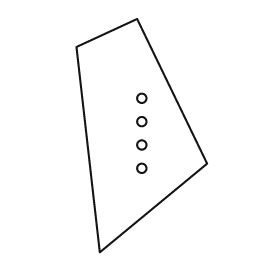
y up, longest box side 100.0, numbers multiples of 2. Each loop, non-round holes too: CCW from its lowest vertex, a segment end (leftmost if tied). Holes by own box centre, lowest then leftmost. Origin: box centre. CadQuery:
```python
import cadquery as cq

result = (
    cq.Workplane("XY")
    .moveTo(-18.0, -50.0)
    .lineTo(28.0, -12.0)
    .lineTo(-2.0, 50.0)
    .lineTo(-28.0, 38.0)
    .close()
    .moveTo(0.0, -14.0)
    .circle(2.0)
    .moveTo(0.0, -4.0)
    .circle(2.0)
    .moveTo(0.0, 6.0)
    .circle(2.0)
    .moveTo(0.0, 16.0)
    .circle(2.0)
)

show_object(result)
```